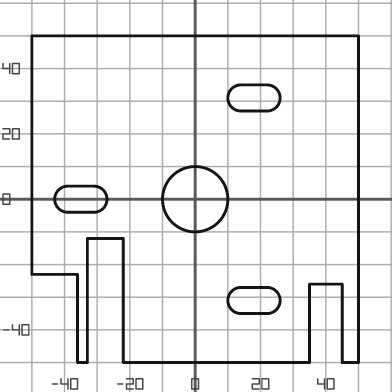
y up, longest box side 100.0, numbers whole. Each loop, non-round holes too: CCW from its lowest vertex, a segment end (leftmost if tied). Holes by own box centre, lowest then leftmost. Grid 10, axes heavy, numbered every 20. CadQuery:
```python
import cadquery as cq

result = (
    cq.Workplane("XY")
    .moveTo(-36.0, -50.0)
    .lineTo(-33.0, -50.0)
    .lineTo(-33.0, -12.0)
    .lineTo(-22.0, -12.0)
    .lineTo(-22.0, -50.0)
    .lineTo(35.0, -50.0)
    .lineTo(35.0, -26.0)
    .lineTo(45.0, -26.0)
    .lineTo(45.0, -50.0)
    .lineTo(50.0, -50.0)
    .lineTo(50.0, 50.0)
    .lineTo(-50.0, 50.0)
    .lineTo(-50.0, -23.0)
    .lineTo(-36.0, -23.0)
    .close()
    .moveTo(14.0, -35.0)
    .lineTo(22.0, -35.0)
    .threePointArc((26.0, -31.0), (22.0, -27.0))
    .lineTo(14.0, -27.0)
    .threePointArc((10.0, -31.0), (14.0, -35.0))
    .close()
    .moveTo(-39.0, -4.0)
    .lineTo(-31.0, -4.0)
    .threePointArc((-27.0, 0.0), (-31.0, 4.0))
    .lineTo(-39.0, 4.0)
    .threePointArc((-43.0, 0.0), (-39.0, -4.0))
    .close()
    .moveTo(0.0, 0.0)
    .circle(10.0)
    .moveTo(14.0, 27.0)
    .lineTo(22.0, 27.0)
    .threePointArc((26.0, 31.0), (22.0, 35.0))
    .lineTo(14.0, 35.0)
    .threePointArc((10.0, 31.0), (14.0, 27.0))
    .close()
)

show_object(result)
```